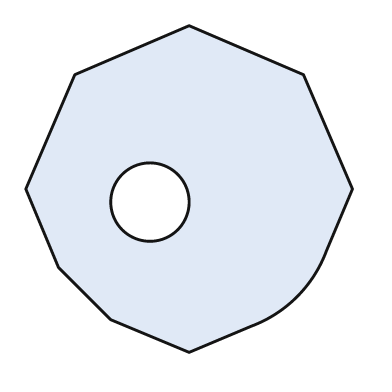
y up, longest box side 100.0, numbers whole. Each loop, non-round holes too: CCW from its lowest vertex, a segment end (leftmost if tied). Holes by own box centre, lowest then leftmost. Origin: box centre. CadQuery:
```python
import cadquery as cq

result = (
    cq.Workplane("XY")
    .moveTo(0.0, -50.0)
    .lineTo(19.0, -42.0)
    .threePointArc((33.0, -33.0), (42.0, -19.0))
    .lineTo(50.0, 0.0)
    .lineTo(35.0, 35.0)
    .lineTo(0.0, 50.0)
    .lineTo(-35.0, 35.0)
    .lineTo(-50.0, 0.0)
    .lineTo(-40.0, -24.0)
    .lineTo(-24.0, -40.0)
    .close()
    .moveTo(-12.0, -4.0)
    .circle(12.0)
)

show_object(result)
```